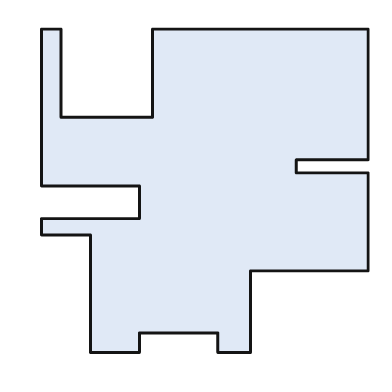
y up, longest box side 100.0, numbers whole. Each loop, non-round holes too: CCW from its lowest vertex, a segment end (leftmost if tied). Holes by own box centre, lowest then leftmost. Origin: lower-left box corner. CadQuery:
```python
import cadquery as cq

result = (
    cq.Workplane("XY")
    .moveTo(15.0, 0.0)
    .lineTo(30.0, 0.0)
    .lineTo(30.0, 6.0)
    .lineTo(54.0, 6.0)
    .lineTo(54.0, 0.0)
    .lineTo(64.0, 0.0)
    .lineTo(64.0, 25.0)
    .lineTo(100.0, 25.0)
    .lineTo(100.0, 55.0)
    .lineTo(78.0, 55.0)
    .lineTo(78.0, 59.0)
    .lineTo(100.0, 59.0)
    .lineTo(100.0, 99.0)
    .lineTo(34.0, 99.0)
    .lineTo(34.0, 72.0)
    .lineTo(6.0, 72.0)
    .lineTo(6.0, 99.0)
    .lineTo(0.0, 99.0)
    .lineTo(0.0, 51.0)
    .lineTo(30.0, 51.0)
    .lineTo(30.0, 41.0)
    .lineTo(0.0, 41.0)
    .lineTo(0.0, 36.0)
    .lineTo(15.0, 36.0)
    .close()
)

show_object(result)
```